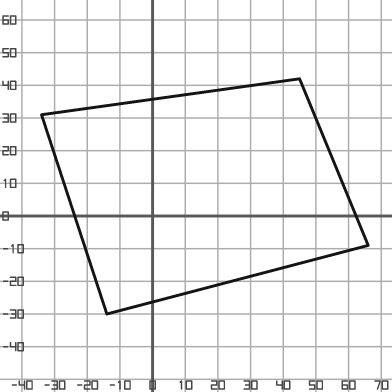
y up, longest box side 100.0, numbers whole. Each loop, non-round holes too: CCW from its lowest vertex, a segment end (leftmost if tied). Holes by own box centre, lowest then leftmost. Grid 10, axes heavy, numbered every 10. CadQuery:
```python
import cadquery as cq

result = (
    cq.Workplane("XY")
    .moveTo(-14.0, -30.0)
    .lineTo(66.0, -9.0)
    .lineTo(45.0, 42.0)
    .lineTo(-34.0, 31.0)
    .close()
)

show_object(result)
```